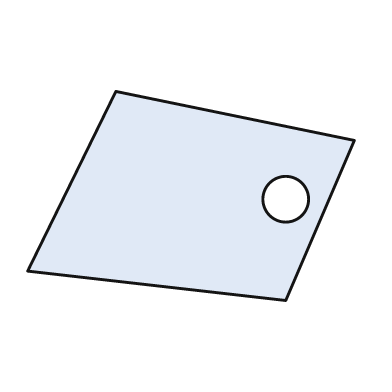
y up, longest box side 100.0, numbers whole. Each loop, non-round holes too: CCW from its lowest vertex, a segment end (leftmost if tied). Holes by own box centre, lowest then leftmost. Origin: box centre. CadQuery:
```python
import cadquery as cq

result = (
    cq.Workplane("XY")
    .moveTo(29.0, -32.0)
    .lineTo(50.0, 17.0)
    .lineTo(-23.0, 32.0)
    .lineTo(-50.0, -23.0)
    .close()
    .moveTo(29.0, -1.0)
    .circle(7.0)
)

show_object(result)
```